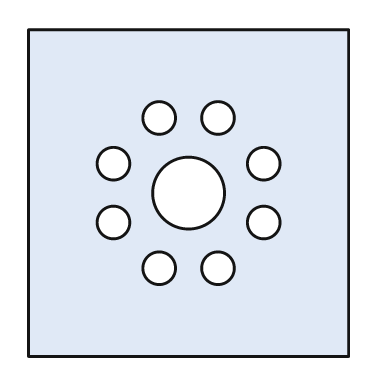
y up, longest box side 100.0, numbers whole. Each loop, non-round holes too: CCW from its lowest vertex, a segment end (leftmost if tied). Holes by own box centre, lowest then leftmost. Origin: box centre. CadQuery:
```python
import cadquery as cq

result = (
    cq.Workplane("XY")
    .moveTo(-49.0, -50.0)
    .lineTo(49.0, -50.0)
    .lineTo(49.0, 50.0)
    .lineTo(-49.0, 50.0)
    .close()
    .moveTo(-9.0, -23.0)
    .circle(5.0)
    .moveTo(9.0, -23.0)
    .circle(5.0)
    .moveTo(-23.0, -9.0)
    .circle(5.0)
    .moveTo(23.0, -9.0)
    .circle(5.0)
    .moveTo(0.0, 0.0)
    .circle(11.0)
    .moveTo(-23.0, 9.0)
    .circle(5.0)
    .moveTo(23.0, 9.0)
    .circle(5.0)
    .moveTo(-9.0, 23.0)
    .circle(5.0)
    .moveTo(9.0, 23.0)
    .circle(5.0)
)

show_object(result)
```